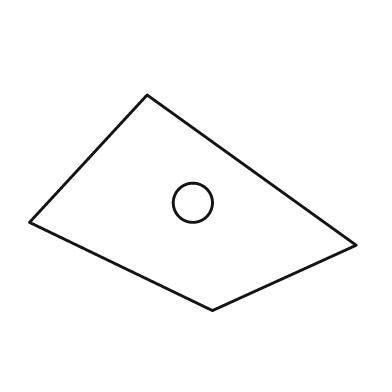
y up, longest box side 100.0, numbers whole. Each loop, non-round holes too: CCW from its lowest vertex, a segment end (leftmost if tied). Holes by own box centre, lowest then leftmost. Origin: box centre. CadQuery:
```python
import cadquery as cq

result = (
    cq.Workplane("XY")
    .moveTo(6.0, -33.0)
    .lineTo(50.0, -13.0)
    .lineTo(-14.0, 33.0)
    .lineTo(-50.0, -6.0)
    .close()
    .moveTo(0.0, 0.0)
    .circle(6.0)
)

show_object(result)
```